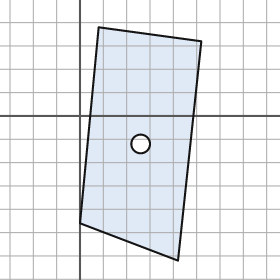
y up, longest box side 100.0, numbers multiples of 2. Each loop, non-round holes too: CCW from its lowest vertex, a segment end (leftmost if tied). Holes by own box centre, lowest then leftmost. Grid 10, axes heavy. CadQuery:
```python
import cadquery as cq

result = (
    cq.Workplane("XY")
    .moveTo(42.0, -62.0)
    .lineTo(52.0, 32.0)
    .lineTo(8.0, 38.0)
    .lineTo(0.0, -46.0)
    .close()
    .moveTo(26.0, -12.0)
    .circle(4.0)
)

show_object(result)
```